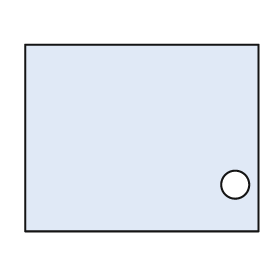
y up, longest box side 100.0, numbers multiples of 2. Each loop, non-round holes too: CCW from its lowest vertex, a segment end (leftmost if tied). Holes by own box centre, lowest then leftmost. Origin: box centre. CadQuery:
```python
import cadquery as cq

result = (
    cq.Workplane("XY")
    .moveTo(-50.0, -40.0)
    .lineTo(50.0, -40.0)
    .lineTo(50.0, 40.0)
    .lineTo(-50.0, 40.0)
    .close()
    .moveTo(40.0, -20.0)
    .circle(6.0)
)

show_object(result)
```